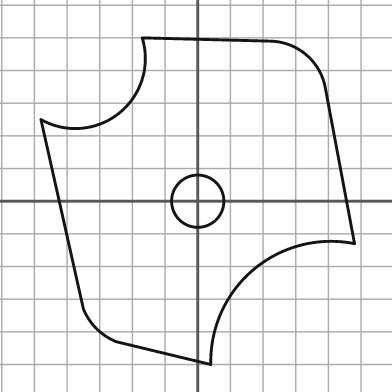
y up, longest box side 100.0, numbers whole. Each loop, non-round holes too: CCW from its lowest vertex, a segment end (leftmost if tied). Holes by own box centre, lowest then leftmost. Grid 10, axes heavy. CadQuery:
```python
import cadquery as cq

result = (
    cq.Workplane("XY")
    .moveTo(4.0, -50.0)
    .threePointArc((17.0, -21.0), (48.0, -13.0))
    .lineTo(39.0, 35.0)
    .threePointArc((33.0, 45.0), (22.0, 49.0))
    .lineTo(-17.0, 50.0)
    .threePointArc((-24.0, 27.0), (-48.0, 25.0))
    .lineTo(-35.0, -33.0)
    .threePointArc((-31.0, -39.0), (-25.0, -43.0))
    .close()
    .moveTo(0.0, 0.0)
    .circle(8.0)
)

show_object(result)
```